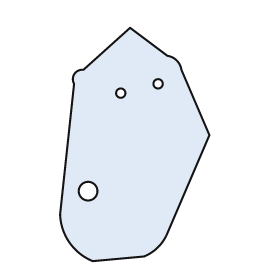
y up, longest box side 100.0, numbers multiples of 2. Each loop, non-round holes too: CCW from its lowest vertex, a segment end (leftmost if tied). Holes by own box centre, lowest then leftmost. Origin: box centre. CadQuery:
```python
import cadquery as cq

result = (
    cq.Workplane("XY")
    .moveTo(-18.0, -50.0)
    .lineTo(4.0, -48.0)
    .threePointArc((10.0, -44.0), (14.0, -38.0))
    .lineTo(32.0, 4.0)
    .lineTo(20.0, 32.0)
    .threePointArc((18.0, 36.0), (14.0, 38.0))
    .lineTo(-2.0, 50.0)
    .lineTo(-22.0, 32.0)
    .threePointArc((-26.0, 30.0), (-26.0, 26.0))
    .lineTo(-32.0, -30.0)
    .threePointArc((-28.0, -42.0), (-18.0, -50.0))
    .close()
    .moveTo(-20.0, -20.0)
    .circle(4.0)
    .moveTo(-6.0, 22.0)
    .circle(2.0)
    .moveTo(10.0, 26.0)
    .circle(2.0)
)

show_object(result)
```